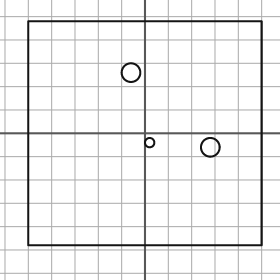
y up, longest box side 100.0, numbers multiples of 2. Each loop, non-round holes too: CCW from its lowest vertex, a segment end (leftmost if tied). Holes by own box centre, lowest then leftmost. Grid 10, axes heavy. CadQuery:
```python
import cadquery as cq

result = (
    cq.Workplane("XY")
    .moveTo(-50.0, -48.0)
    .lineTo(50.0, -48.0)
    .lineTo(50.0, 48.0)
    .lineTo(-50.0, 48.0)
    .close()
    .moveTo(28.0, -6.0)
    .circle(4.0)
    .moveTo(2.0, -4.0)
    .circle(2.0)
    .moveTo(-6.0, 26.0)
    .circle(4.0)
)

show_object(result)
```